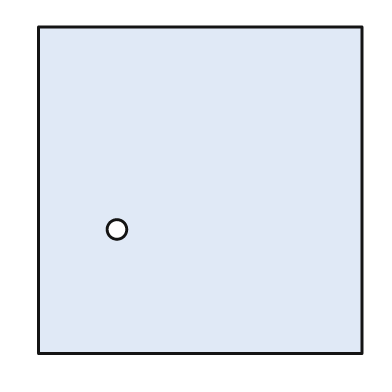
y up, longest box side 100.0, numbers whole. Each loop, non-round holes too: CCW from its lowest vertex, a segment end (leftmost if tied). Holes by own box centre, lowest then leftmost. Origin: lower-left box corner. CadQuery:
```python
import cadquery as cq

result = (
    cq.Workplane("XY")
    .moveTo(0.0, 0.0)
    .lineTo(99.0, 0.0)
    .lineTo(99.0, 100.0)
    .lineTo(0.0, 100.0)
    .close()
    .moveTo(24.0, 38.0)
    .circle(3.0)
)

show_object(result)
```